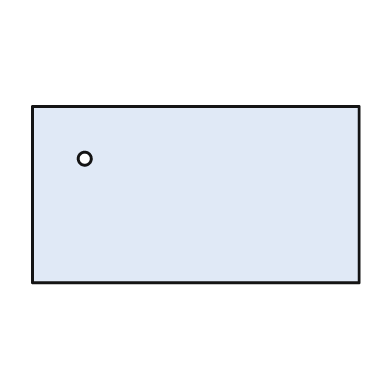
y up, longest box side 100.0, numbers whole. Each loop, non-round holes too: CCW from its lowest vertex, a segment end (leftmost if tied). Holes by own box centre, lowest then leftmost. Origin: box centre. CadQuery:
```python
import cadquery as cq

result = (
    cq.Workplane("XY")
    .moveTo(-50.0, -27.0)
    .lineTo(50.0, -27.0)
    .lineTo(50.0, 27.0)
    .lineTo(-50.0, 27.0)
    .close()
    .moveTo(-34.0, 11.0)
    .circle(2.0)
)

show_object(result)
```